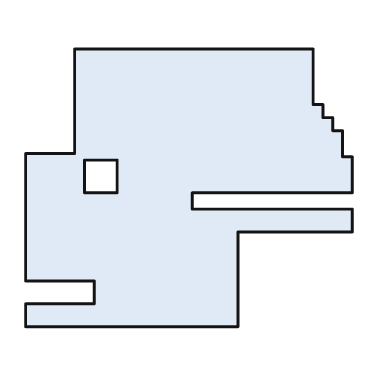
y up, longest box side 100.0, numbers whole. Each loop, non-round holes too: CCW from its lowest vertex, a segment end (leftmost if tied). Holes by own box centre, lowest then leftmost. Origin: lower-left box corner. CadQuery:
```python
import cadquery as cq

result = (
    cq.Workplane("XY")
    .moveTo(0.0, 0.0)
    .lineTo(65.0, 0.0)
    .lineTo(65.0, 29.0)
    .lineTo(100.0, 29.0)
    .lineTo(100.0, 36.0)
    .lineTo(51.0, 36.0)
    .lineTo(51.0, 41.0)
    .lineTo(100.0, 41.0)
    .lineTo(100.0, 52.0)
    .lineTo(97.0, 52.0)
    .lineTo(97.0, 60.0)
    .lineTo(94.0, 60.0)
    .lineTo(94.0, 64.0)
    .lineTo(91.0, 64.0)
    .lineTo(91.0, 68.0)
    .lineTo(88.0, 68.0)
    .lineTo(88.0, 85.0)
    .lineTo(15.0, 85.0)
    .lineTo(15.0, 53.0)
    .lineTo(0.0, 53.0)
    .lineTo(0.0, 14.0)
    .lineTo(21.0, 14.0)
    .lineTo(21.0, 7.0)
    .lineTo(0.0, 7.0)
    .close()
    .moveTo(18.0, 41.0)
    .lineTo(28.0, 41.0)
    .lineTo(28.0, 51.0)
    .lineTo(18.0, 51.0)
    .close()
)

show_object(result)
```